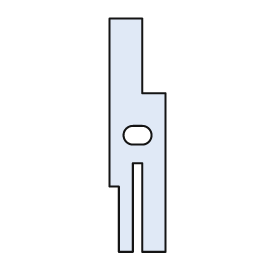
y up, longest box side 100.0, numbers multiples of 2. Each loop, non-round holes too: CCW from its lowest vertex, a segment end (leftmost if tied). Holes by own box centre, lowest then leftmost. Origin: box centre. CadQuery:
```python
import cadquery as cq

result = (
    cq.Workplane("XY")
    .moveTo(-8.0, -50.0)
    .lineTo(-2.0, -50.0)
    .lineTo(-2.0, -12.0)
    .lineTo(2.0, -12.0)
    .lineTo(2.0, -50.0)
    .lineTo(12.0, -50.0)
    .lineTo(12.0, 18.0)
    .lineTo(2.0, 18.0)
    .lineTo(2.0, 50.0)
    .lineTo(-12.0, 50.0)
    .lineTo(-12.0, -22.0)
    .lineTo(-8.0, -22.0)
    .close()
    .moveTo(-2.0, -4.0)
    .lineTo(2.0, -4.0)
    .threePointArc((6.0, 0.0), (2.0, 4.0))
    .lineTo(-2.0, 4.0)
    .threePointArc((-6.0, 0.0), (-2.0, -4.0))
    .close()
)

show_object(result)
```